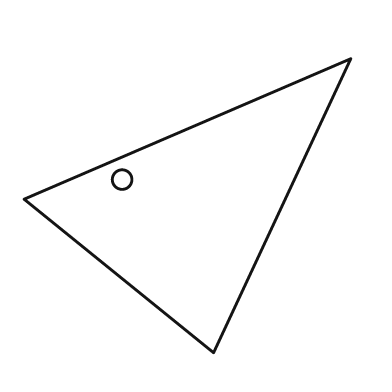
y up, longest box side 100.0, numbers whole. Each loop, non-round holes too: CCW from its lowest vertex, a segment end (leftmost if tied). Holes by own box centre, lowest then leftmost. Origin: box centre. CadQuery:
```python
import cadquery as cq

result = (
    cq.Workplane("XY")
    .moveTo(8.0, -45.0)
    .lineTo(50.0, 45.0)
    .lineTo(-50.0, 2.0)
    .close()
    .moveTo(-20.0, 8.0)
    .circle(3.0)
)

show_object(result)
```